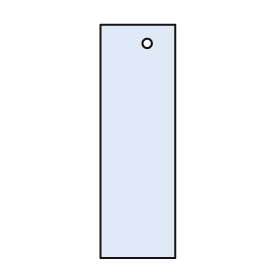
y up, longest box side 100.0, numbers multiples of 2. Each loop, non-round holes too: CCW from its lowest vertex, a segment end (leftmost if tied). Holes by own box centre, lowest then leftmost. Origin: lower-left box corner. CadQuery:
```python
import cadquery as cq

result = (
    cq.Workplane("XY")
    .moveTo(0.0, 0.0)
    .lineTo(32.0, 0.0)
    .lineTo(32.0, 100.0)
    .lineTo(0.0, 100.0)
    .close()
    .moveTo(20.0, 92.0)
    .circle(2.0)
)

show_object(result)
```